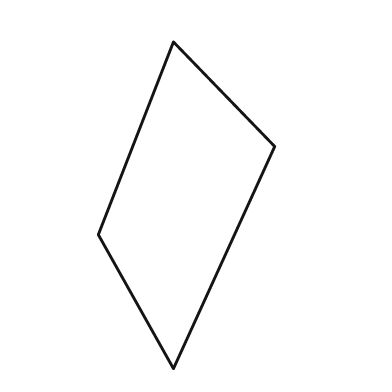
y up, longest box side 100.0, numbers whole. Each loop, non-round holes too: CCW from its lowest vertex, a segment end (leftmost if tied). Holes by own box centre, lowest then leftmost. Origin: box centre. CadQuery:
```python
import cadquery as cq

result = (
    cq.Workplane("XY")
    .moveTo(-4.0, -50.0)
    .lineTo(27.0, 18.0)
    .lineTo(-4.0, 50.0)
    .lineTo(-27.0, -9.0)
    .close()
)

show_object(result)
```